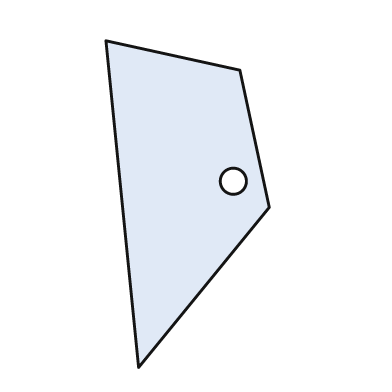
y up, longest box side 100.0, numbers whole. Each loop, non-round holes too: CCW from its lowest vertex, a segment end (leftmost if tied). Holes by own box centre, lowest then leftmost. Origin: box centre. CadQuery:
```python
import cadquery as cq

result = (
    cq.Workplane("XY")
    .moveTo(-15.0, -50.0)
    .lineTo(25.0, -1.0)
    .lineTo(16.0, 41.0)
    .lineTo(-25.0, 50.0)
    .close()
    .moveTo(14.0, 7.0)
    .circle(4.0)
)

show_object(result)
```